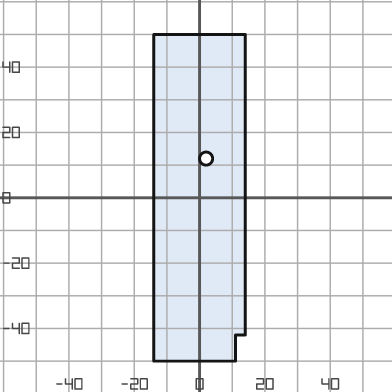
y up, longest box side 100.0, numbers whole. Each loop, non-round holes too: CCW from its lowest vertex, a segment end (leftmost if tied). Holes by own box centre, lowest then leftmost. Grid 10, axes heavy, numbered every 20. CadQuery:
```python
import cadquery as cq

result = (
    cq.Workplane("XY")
    .moveTo(-14.0, -50.0)
    .lineTo(11.0, -50.0)
    .lineTo(11.0, -42.0)
    .lineTo(14.0, -42.0)
    .lineTo(14.0, 50.0)
    .lineTo(-14.0, 50.0)
    .close()
    .moveTo(2.0, 12.0)
    .circle(2.0)
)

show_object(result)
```